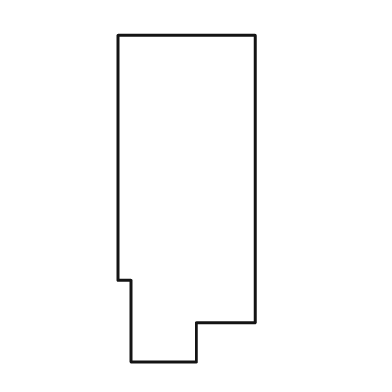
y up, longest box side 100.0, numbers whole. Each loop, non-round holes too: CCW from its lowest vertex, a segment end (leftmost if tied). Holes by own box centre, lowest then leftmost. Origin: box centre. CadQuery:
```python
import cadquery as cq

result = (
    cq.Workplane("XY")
    .moveTo(-17.0, -50.0)
    .lineTo(3.0, -50.0)
    .lineTo(3.0, -38.0)
    .lineTo(21.0, -38.0)
    .lineTo(21.0, 50.0)
    .lineTo(-21.0, 50.0)
    .lineTo(-21.0, -25.0)
    .lineTo(-17.0, -25.0)
    .close()
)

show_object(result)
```